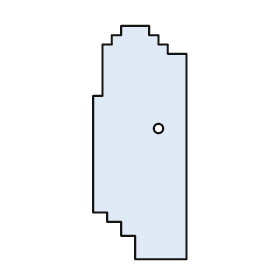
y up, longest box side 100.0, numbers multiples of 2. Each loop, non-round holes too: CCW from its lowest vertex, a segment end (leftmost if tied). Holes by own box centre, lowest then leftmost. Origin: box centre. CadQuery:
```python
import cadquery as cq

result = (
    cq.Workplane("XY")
    .moveTo(-2.0, -50.0)
    .lineTo(20.0, -50.0)
    .lineTo(20.0, 38.0)
    .lineTo(12.0, 38.0)
    .lineTo(12.0, 42.0)
    .lineTo(8.0, 42.0)
    .lineTo(8.0, 46.0)
    .lineTo(4.0, 46.0)
    .lineTo(4.0, 50.0)
    .lineTo(-8.0, 50.0)
    .lineTo(-8.0, 46.0)
    .lineTo(-12.0, 46.0)
    .lineTo(-12.0, 42.0)
    .lineTo(-16.0, 42.0)
    .lineTo(-16.0, 20.0)
    .lineTo(-20.0, 20.0)
    .lineTo(-20.0, -30.0)
    .lineTo(-14.0, -30.0)
    .lineTo(-14.0, -34.0)
    .lineTo(-8.0, -34.0)
    .lineTo(-8.0, -40.0)
    .lineTo(-2.0, -40.0)
    .close()
    .moveTo(8.0, 6.0)
    .circle(2.0)
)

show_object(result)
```